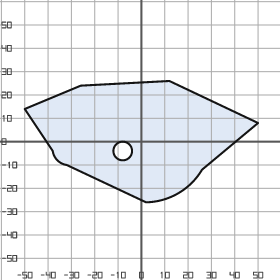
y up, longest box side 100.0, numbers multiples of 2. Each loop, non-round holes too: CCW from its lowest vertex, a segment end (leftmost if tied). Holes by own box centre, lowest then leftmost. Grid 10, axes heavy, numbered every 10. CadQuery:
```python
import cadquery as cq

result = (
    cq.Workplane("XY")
    .moveTo(2.0, -26.0)
    .threePointArc((16.0, -22.0), (26.0, -12.0))
    .lineTo(50.0, 8.0)
    .lineTo(12.0, 26.0)
    .lineTo(-26.0, 24.0)
    .lineTo(-50.0, 14.0)
    .lineTo(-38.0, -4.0)
    .threePointArc((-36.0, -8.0), (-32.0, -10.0))
    .close()
    .moveTo(-8.0, -4.0)
    .circle(4.0)
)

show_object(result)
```